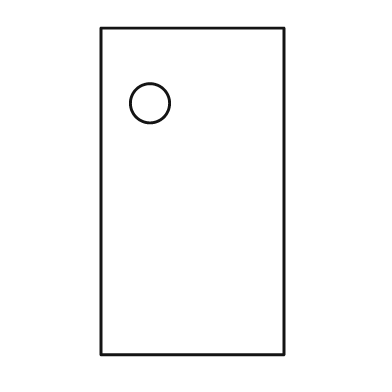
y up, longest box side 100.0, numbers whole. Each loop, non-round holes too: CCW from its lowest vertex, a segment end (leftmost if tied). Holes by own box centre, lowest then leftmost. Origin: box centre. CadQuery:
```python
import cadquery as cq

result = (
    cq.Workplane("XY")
    .moveTo(-28.0, -50.0)
    .lineTo(28.0, -50.0)
    .lineTo(28.0, 50.0)
    .lineTo(-28.0, 50.0)
    .close()
    .moveTo(-13.0, 27.0)
    .circle(6.0)
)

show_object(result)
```